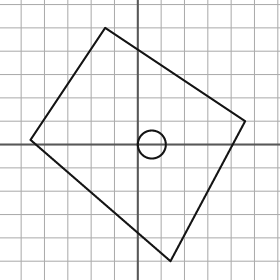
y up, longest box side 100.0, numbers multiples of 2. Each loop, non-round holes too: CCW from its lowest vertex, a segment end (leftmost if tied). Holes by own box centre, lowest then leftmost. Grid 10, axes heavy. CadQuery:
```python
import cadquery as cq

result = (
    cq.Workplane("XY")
    .moveTo(14.0, -50.0)
    .lineTo(46.0, 10.0)
    .lineTo(-14.0, 50.0)
    .lineTo(-46.0, 2.0)
    .close()
    .moveTo(6.0, 0.0)
    .circle(6.0)
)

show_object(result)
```